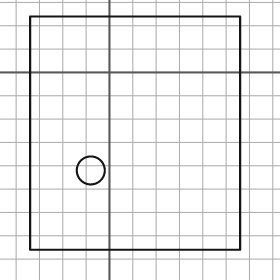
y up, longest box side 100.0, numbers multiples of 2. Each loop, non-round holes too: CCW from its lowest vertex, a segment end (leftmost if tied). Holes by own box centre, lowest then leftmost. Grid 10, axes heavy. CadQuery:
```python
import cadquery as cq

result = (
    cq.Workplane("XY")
    .moveTo(-34.0, -76.0)
    .lineTo(56.0, -76.0)
    .lineTo(56.0, 24.0)
    .lineTo(-34.0, 24.0)
    .close()
    .moveTo(-8.0, -42.0)
    .circle(6.0)
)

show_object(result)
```